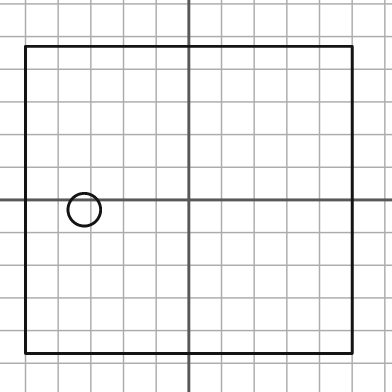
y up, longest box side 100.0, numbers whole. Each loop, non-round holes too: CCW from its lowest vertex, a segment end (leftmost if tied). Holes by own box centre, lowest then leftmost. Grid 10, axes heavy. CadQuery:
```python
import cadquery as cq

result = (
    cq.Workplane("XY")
    .moveTo(-50.0, -47.0)
    .lineTo(50.0, -47.0)
    .lineTo(50.0, 47.0)
    .lineTo(-50.0, 47.0)
    .close()
    .moveTo(-32.0, -3.0)
    .circle(5.0)
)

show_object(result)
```